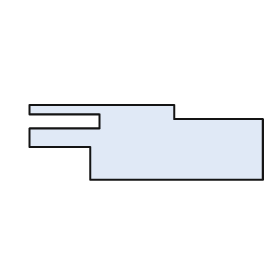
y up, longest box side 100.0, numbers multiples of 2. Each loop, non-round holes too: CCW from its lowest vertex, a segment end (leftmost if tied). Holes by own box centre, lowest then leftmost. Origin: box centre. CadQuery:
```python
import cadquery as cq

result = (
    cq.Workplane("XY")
    .moveTo(-24.0, -16.0)
    .lineTo(50.0, -16.0)
    .lineTo(50.0, 10.0)
    .lineTo(12.0, 10.0)
    .lineTo(12.0, 16.0)
    .lineTo(-50.0, 16.0)
    .lineTo(-50.0, 12.0)
    .lineTo(-20.0, 12.0)
    .lineTo(-20.0, 6.0)
    .lineTo(-50.0, 6.0)
    .lineTo(-50.0, -2.0)
    .lineTo(-24.0, -2.0)
    .close()
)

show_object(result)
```